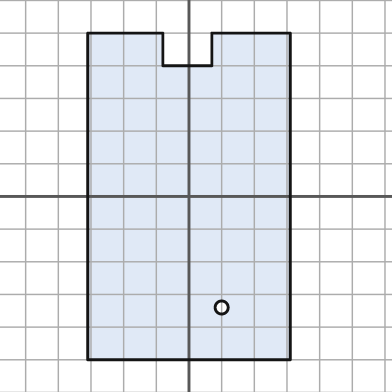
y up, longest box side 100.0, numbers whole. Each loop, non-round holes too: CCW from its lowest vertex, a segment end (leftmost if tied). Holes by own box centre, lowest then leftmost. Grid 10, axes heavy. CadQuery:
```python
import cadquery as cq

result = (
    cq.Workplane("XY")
    .moveTo(-31.0, -50.0)
    .lineTo(31.0, -50.0)
    .lineTo(31.0, 50.0)
    .lineTo(7.0, 50.0)
    .lineTo(7.0, 40.0)
    .lineTo(-8.0, 40.0)
    .lineTo(-8.0, 50.0)
    .lineTo(-31.0, 50.0)
    .close()
    .moveTo(10.0, -34.0)
    .circle(2.0)
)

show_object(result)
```